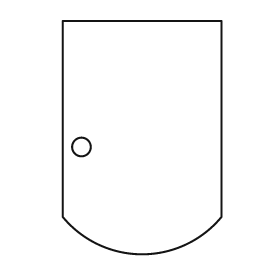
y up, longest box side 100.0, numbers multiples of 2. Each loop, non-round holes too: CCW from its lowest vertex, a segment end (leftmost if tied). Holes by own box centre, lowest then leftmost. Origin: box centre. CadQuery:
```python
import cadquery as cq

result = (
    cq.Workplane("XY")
    .moveTo(-34.0, -34.0)
    .threePointArc((0.0, -50.0), (34.0, -34.0))
    .lineTo(34.0, 50.0)
    .lineTo(-34.0, 50.0)
    .close()
    .moveTo(-26.0, -4.0)
    .circle(4.0)
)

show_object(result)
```